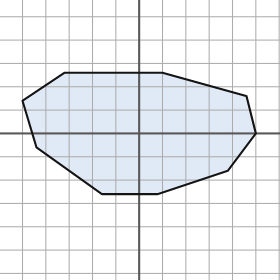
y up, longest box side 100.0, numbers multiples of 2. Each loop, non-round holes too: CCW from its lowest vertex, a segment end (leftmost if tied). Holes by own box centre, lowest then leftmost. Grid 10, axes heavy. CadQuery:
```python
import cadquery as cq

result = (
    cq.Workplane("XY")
    .moveTo(-16.0, -26.0)
    .lineTo(8.0, -26.0)
    .lineTo(38.0, -16.0)
    .lineTo(50.0, 0.0)
    .lineTo(46.0, 16.0)
    .lineTo(10.0, 26.0)
    .lineTo(-32.0, 26.0)
    .lineTo(-50.0, 14.0)
    .lineTo(-44.0, -6.0)
    .close()
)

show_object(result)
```